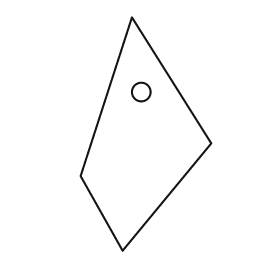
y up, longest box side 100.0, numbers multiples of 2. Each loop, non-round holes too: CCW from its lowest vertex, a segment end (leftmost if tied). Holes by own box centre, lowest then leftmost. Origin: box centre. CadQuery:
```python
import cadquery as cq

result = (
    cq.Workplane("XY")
    .moveTo(-10.0, -50.0)
    .lineTo(28.0, -4.0)
    .lineTo(-6.0, 50.0)
    .lineTo(-28.0, -18.0)
    .close()
    .moveTo(-2.0, 18.0)
    .circle(4.0)
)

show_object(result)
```